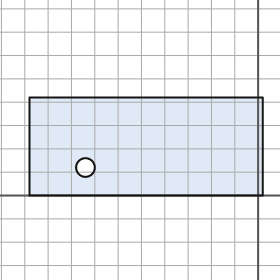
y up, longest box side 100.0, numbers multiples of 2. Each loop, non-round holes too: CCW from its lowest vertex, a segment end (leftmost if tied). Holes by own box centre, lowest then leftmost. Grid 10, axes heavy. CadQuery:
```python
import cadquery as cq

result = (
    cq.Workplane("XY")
    .moveTo(-98.0, 0.0)
    .lineTo(2.0, 0.0)
    .lineTo(2.0, 42.0)
    .lineTo(-98.0, 42.0)
    .close()
    .moveTo(-74.0, 12.0)
    .circle(4.0)
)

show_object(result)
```